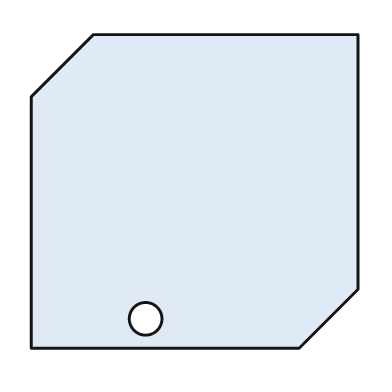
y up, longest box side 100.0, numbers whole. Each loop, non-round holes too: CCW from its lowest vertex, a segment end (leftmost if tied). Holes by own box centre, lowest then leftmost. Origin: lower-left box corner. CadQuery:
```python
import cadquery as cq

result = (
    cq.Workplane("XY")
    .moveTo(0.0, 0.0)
    .lineTo(82.0, 0.0)
    .lineTo(100.0, 18.0)
    .lineTo(100.0, 96.0)
    .lineTo(19.0, 96.0)
    .lineTo(0.0, 77.0)
    .close()
    .moveTo(35.0, 9.0)
    .circle(5.0)
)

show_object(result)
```